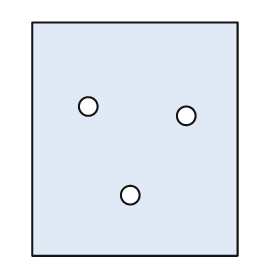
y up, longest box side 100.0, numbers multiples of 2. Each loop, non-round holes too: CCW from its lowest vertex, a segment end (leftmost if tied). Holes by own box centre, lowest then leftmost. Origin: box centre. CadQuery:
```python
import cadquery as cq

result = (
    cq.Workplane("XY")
    .moveTo(-44.0, -50.0)
    .lineTo(44.0, -50.0)
    .lineTo(44.0, 50.0)
    .lineTo(-44.0, 50.0)
    .close()
    .moveTo(-2.0, -24.0)
    .circle(4.0)
    .moveTo(22.0, 10.0)
    .circle(4.0)
    .moveTo(-20.0, 14.0)
    .circle(4.0)
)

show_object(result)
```